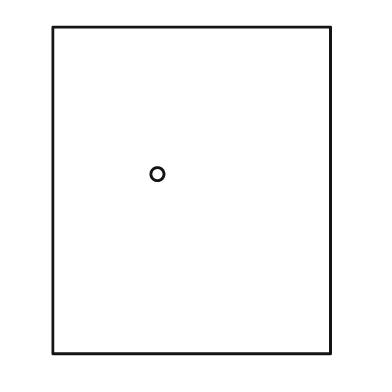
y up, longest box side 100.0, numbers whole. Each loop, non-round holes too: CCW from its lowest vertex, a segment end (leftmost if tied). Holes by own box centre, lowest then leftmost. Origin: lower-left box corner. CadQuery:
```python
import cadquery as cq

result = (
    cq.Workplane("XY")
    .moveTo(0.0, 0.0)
    .lineTo(85.0, 0.0)
    .lineTo(85.0, 100.0)
    .lineTo(0.0, 100.0)
    .close()
    .moveTo(32.0, 55.0)
    .circle(2.0)
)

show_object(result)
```